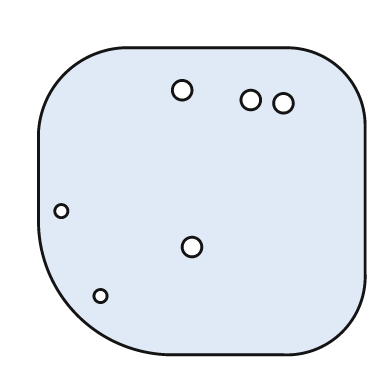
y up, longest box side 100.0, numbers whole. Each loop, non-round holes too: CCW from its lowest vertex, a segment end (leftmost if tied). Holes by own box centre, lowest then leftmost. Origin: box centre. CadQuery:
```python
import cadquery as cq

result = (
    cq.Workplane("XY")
    .moveTo(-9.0, -47.0)
    .lineTo(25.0, -47.0)
    .threePointArc((43.0, -40.0), (50.0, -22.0))
    .lineTo(50.0, 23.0)
    .threePointArc((43.0, 40.0), (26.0, 47.0))
    .lineTo(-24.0, 47.0)
    .threePointArc((-42.0, 39.0), (-50.0, 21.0))
    .lineTo(-50.0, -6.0)
    .threePointArc((-38.0, -35.0), (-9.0, -47.0))
    .close()
    .moveTo(-31.0, -29.0)
    .circle(2.0)
    .moveTo(-3.0, -14.0)
    .circle(3.0)
    .moveTo(-43.0, -3.0)
    .circle(2.0)
    .moveTo(25.0, 30.0)
    .circle(3.0)
    .moveTo(15.0, 31.0)
    .circle(3.0)
    .moveTo(-6.0, 34.0)
    .circle(3.0)
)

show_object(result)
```